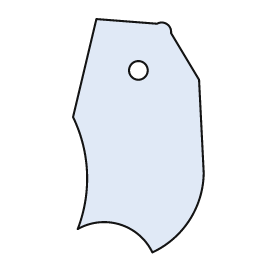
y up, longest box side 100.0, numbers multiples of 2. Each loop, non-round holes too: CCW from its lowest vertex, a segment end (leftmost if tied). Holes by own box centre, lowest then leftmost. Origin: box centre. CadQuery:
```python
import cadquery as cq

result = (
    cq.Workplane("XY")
    .moveTo(6.0, -50.0)
    .threePointArc((22.0, -36.0), (28.0, -16.0))
    .lineTo(26.0, 24.0)
    .lineTo(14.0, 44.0)
    .threePointArc((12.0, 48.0), (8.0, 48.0))
    .lineTo(-18.0, 50.0)
    .lineTo(-28.0, 8.0)
    .threePointArc((-22.0, -16.0), (-26.0, -40.0))
    .threePointArc((-8.0, -38.0), (6.0, -50.0))
    .close()
    .moveTo(0.0, 28.0)
    .circle(4.0)
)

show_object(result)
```